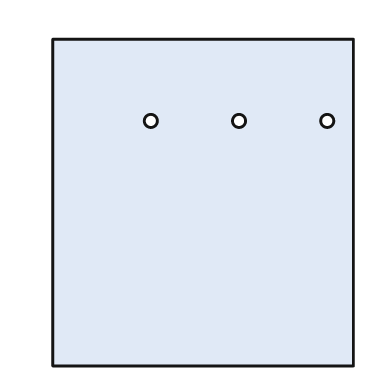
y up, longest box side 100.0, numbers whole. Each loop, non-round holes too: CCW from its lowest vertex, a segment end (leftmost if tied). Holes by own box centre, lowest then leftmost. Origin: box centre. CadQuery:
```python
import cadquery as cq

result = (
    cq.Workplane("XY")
    .moveTo(-46.0, -50.0)
    .lineTo(46.0, -50.0)
    .lineTo(46.0, 50.0)
    .lineTo(-46.0, 50.0)
    .close()
    .moveTo(-16.0, 25.0)
    .circle(2.0)
    .moveTo(11.0, 25.0)
    .circle(2.0)
    .moveTo(38.0, 25.0)
    .circle(2.0)
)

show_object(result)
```